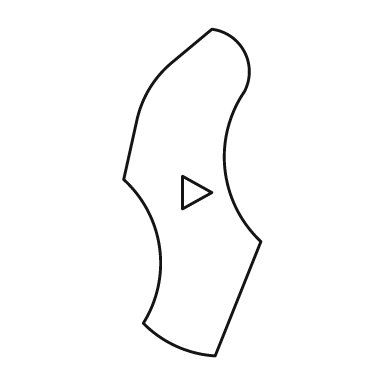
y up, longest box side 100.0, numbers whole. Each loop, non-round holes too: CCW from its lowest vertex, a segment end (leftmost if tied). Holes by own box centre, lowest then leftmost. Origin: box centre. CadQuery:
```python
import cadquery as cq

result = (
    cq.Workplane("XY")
    .moveTo(7.0, -50.0)
    .lineTo(21.0, -15.0)
    .threePointArc((10.0, 7.0), (16.0, 31.0))
    .threePointArc((16.0, 43.0), (6.0, 50.0))
    .lineTo(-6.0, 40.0)
    .threePointArc((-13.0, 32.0), (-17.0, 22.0))
    .lineTo(-21.0, 4.0)
    .threePointArc((-10.0, -17.0), (-15.0, -40.0))
    .threePointArc((-5.0, -47.0), (7.0, -50.0))
    .close()
    .moveTo(-3.0, -5.0)
    .lineTo(6.0, 0.0)
    .lineTo(-3.0, 5.0)
    .close()
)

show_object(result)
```